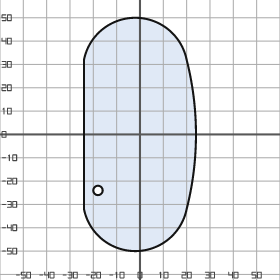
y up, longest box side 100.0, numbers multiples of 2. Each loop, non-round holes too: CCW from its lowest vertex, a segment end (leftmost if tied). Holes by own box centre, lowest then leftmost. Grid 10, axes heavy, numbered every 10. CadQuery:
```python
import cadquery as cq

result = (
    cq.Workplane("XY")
    .moveTo(-24.0, -32.0)
    .threePointArc((-2.0, -50.0), (20.0, -32.0))
    .threePointArc((24.0, 0.0), (20.0, 32.0))
    .threePointArc((-2.0, 50.0), (-24.0, 32.0))
    .close()
    .moveTo(-18.0, -24.0)
    .circle(2.0)
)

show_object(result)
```